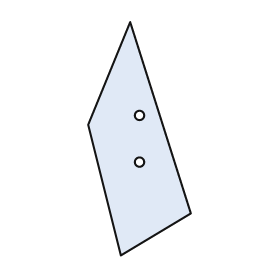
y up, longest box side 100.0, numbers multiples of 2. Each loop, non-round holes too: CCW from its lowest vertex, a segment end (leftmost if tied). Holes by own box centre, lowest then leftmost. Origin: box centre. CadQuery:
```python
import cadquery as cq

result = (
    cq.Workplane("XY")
    .moveTo(-8.0, -50.0)
    .lineTo(22.0, -32.0)
    .lineTo(-4.0, 50.0)
    .lineTo(-22.0, 6.0)
    .close()
    .moveTo(0.0, -10.0)
    .circle(2.0)
    .moveTo(0.0, 10.0)
    .circle(2.0)
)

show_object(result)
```